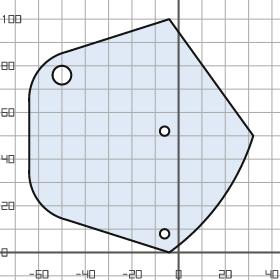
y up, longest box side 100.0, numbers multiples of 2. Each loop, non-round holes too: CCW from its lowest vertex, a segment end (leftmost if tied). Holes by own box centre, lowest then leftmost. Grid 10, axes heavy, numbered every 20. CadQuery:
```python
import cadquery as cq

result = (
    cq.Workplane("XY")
    .moveTo(-4.0, 0.0)
    .threePointArc((18.0, 22.0), (32.0, 50.0))
    .lineTo(-4.0, 100.0)
    .lineTo(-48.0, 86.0)
    .threePointArc((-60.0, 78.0), (-64.0, 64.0))
    .lineTo(-64.0, 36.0)
    .threePointArc((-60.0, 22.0), (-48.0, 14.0))
    .close()
    .moveTo(-6.0, 8.0)
    .circle(2.0)
    .moveTo(-6.0, 52.0)
    .circle(2.0)
    .moveTo(-50.0, 76.0)
    .circle(4.0)
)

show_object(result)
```